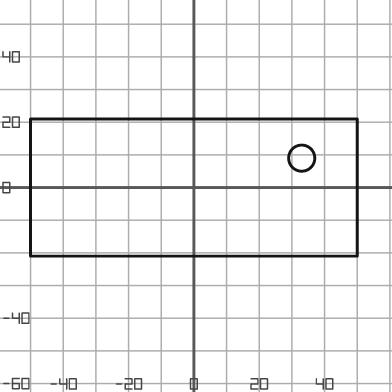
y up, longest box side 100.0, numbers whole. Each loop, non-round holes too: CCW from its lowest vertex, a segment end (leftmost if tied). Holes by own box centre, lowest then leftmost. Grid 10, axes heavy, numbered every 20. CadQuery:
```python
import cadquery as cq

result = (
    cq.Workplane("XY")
    .moveTo(-50.0, -21.0)
    .lineTo(50.0, -21.0)
    .lineTo(50.0, 21.0)
    .lineTo(-50.0, 21.0)
    .close()
    .moveTo(33.0, 9.0)
    .circle(4.0)
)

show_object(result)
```